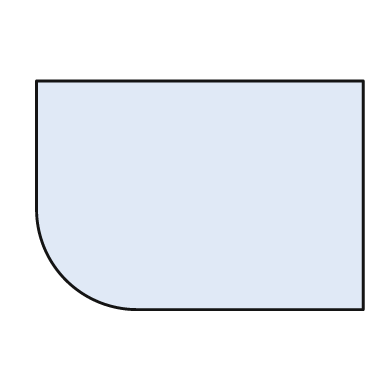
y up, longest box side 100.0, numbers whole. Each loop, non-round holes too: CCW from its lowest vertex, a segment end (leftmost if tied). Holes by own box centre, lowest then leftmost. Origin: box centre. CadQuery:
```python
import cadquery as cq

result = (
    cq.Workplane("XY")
    .moveTo(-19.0, -35.0)
    .lineTo(50.0, -35.0)
    .lineTo(50.0, 35.0)
    .lineTo(-50.0, 35.0)
    .lineTo(-50.0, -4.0)
    .threePointArc((-41.0, -26.0), (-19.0, -35.0))
    .close()
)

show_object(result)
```